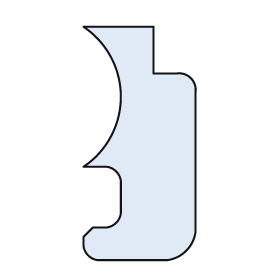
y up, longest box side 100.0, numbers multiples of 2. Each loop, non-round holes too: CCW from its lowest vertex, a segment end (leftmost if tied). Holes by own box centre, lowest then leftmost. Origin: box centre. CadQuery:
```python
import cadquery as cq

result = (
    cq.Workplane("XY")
    .moveTo(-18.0, -50.0)
    .lineTo(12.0, -50.0)
    .threePointArc((20.0, -46.0), (24.0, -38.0))
    .lineTo(24.0, 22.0)
    .threePointArc((22.0, 28.0), (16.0, 30.0))
    .lineTo(6.0, 30.0)
    .lineTo(6.0, 50.0)
    .lineTo(-24.0, 50.0)
    .threePointArc((-8.0, 20.0), (-24.0, -10.0))
    .lineTo(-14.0, -10.0)
    .threePointArc((-10.0, -12.0), (-8.0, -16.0))
    .lineTo(-8.0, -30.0)
    .threePointArc((-10.0, -34.0), (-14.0, -36.0))
    .lineTo(-20.0, -36.0)
    .lineTo(-24.0, -40.0)
    .lineTo(-24.0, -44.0)
    .threePointArc((-22.0, -48.0), (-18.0, -50.0))
    .close()
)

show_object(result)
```